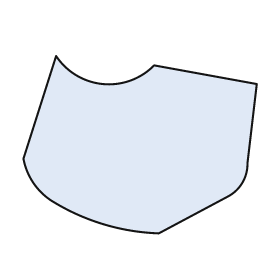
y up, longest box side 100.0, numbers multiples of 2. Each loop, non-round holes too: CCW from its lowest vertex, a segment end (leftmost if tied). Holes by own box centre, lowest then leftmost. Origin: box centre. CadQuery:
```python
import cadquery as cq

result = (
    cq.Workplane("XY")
    .moveTo(8.0, -38.0)
    .lineTo(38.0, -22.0)
    .threePointArc((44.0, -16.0), (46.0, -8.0))
    .lineTo(50.0, 26.0)
    .lineTo(6.0, 34.0)
    .threePointArc((-16.0, 26.0), (-36.0, 38.0))
    .lineTo(-50.0, -6.0)
    .threePointArc((-46.0, -16.0), (-38.0, -24.0))
    .threePointArc((-16.0, -34.0), (8.0, -38.0))
    .close()
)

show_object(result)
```